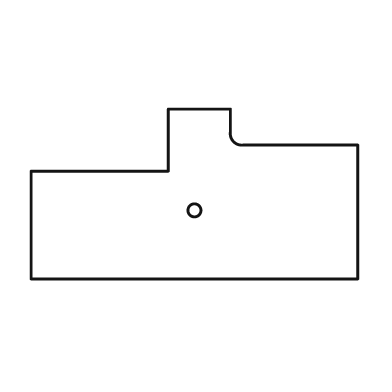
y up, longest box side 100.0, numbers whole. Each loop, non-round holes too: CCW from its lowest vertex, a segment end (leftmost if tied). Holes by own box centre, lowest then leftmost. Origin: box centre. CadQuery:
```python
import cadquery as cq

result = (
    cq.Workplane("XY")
    .moveTo(-50.0, -26.0)
    .lineTo(50.0, -26.0)
    .lineTo(50.0, 15.0)
    .lineTo(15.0, 15.0)
    .threePointArc((12.0, 16.0), (11.0, 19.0))
    .lineTo(11.0, 26.0)
    .lineTo(-8.0, 26.0)
    .lineTo(-8.0, 7.0)
    .lineTo(-50.0, 7.0)
    .close()
    .moveTo(0.0, -5.0)
    .circle(2.0)
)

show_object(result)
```